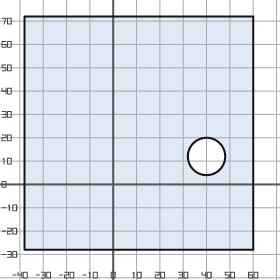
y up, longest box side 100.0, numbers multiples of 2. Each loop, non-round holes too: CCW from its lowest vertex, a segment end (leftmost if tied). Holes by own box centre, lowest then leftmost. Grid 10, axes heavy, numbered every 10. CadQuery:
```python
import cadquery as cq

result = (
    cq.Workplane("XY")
    .moveTo(-38.0, -28.0)
    .lineTo(60.0, -28.0)
    .lineTo(60.0, 72.0)
    .lineTo(-38.0, 72.0)
    .close()
    .moveTo(40.0, 12.0)
    .circle(8.0)
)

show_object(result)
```